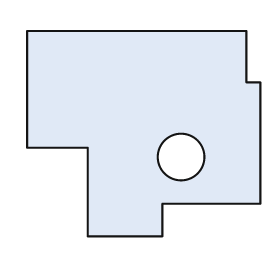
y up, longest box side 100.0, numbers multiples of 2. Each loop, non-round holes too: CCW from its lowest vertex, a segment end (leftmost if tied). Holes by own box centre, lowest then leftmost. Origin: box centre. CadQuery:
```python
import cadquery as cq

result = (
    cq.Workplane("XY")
    .moveTo(-24.0, -44.0)
    .lineTo(8.0, -44.0)
    .lineTo(8.0, -30.0)
    .lineTo(50.0, -30.0)
    .lineTo(50.0, 22.0)
    .lineTo(44.0, 22.0)
    .lineTo(44.0, 44.0)
    .lineTo(-50.0, 44.0)
    .lineTo(-50.0, -6.0)
    .lineTo(-24.0, -6.0)
    .close()
    .moveTo(16.0, -10.0)
    .circle(10.0)
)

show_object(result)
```